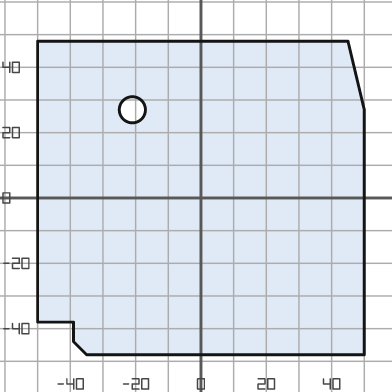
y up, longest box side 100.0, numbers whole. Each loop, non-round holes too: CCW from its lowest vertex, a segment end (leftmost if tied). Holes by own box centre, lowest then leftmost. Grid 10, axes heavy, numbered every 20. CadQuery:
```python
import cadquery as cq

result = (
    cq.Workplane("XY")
    .moveTo(-35.0, -48.0)
    .lineTo(50.0, -48.0)
    .lineTo(50.0, 27.0)
    .lineTo(45.0, 48.0)
    .lineTo(-50.0, 48.0)
    .lineTo(-50.0, -38.0)
    .lineTo(-39.0, -38.0)
    .lineTo(-39.0, -44.0)
    .close()
    .moveTo(-21.0, 27.0)
    .circle(4.0)
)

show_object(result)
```